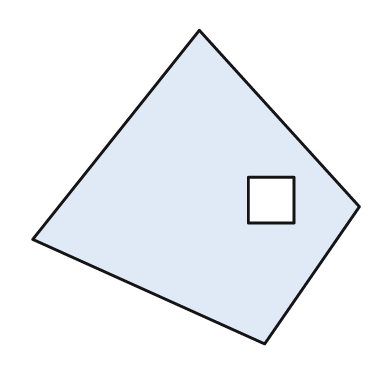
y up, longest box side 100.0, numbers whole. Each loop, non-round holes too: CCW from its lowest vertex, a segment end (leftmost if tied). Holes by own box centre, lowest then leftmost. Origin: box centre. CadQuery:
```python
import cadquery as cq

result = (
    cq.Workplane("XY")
    .moveTo(21.0, -48.0)
    .lineTo(50.0, -6.0)
    .lineTo(1.0, 48.0)
    .lineTo(-50.0, -16.0)
    .close()
    .moveTo(16.0, -11.0)
    .lineTo(30.0, -11.0)
    .lineTo(30.0, 3.0)
    .lineTo(16.0, 3.0)
    .close()
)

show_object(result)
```